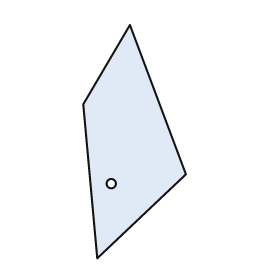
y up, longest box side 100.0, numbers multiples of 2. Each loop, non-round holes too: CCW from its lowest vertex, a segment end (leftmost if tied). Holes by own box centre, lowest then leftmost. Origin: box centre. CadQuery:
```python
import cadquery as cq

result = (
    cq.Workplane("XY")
    .moveTo(-16.0, -50.0)
    .lineTo(22.0, -14.0)
    .lineTo(-2.0, 50.0)
    .lineTo(-22.0, 16.0)
    .close()
    .moveTo(-10.0, -18.0)
    .circle(2.0)
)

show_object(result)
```